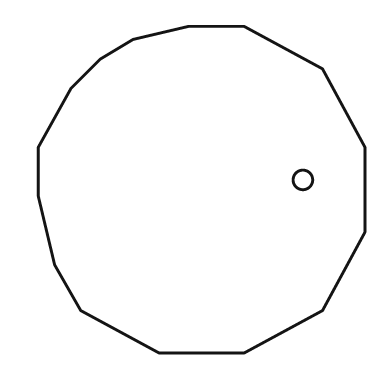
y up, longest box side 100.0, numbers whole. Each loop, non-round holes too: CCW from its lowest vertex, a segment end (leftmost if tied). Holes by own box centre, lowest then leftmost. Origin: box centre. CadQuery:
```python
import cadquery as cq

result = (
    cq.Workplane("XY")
    .moveTo(-13.0, -50.0)
    .lineTo(13.0, -50.0)
    .lineTo(37.0, -37.0)
    .lineTo(50.0, -13.0)
    .lineTo(50.0, 13.0)
    .lineTo(37.0, 37.0)
    .lineTo(13.0, 50.0)
    .lineTo(-4.0, 50.0)
    .lineTo(-21.0, 46.0)
    .lineTo(-31.0, 40.0)
    .lineTo(-40.0, 31.0)
    .lineTo(-50.0, 13.0)
    .lineTo(-50.0, -2.0)
    .lineTo(-45.0, -23.0)
    .lineTo(-37.0, -37.0)
    .close()
    .moveTo(31.0, 3.0)
    .circle(3.0)
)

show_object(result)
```